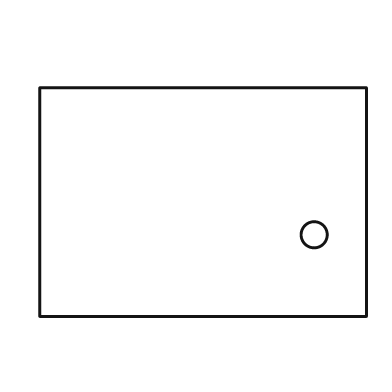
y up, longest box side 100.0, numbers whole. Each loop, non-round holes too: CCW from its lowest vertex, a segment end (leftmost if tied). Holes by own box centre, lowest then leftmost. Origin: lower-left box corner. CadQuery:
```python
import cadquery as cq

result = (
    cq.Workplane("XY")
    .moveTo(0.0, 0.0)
    .lineTo(100.0, 0.0)
    .lineTo(100.0, 70.0)
    .lineTo(0.0, 70.0)
    .close()
    .moveTo(84.0, 25.0)
    .circle(4.0)
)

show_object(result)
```